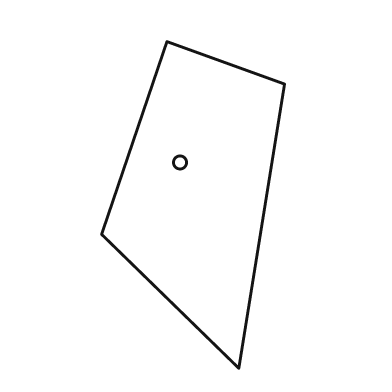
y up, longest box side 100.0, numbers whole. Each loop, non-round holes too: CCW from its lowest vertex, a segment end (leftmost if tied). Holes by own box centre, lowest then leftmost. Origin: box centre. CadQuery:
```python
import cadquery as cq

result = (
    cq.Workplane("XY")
    .moveTo(14.0, -50.0)
    .lineTo(28.0, 37.0)
    .lineTo(-8.0, 50.0)
    .lineTo(-28.0, -9.0)
    .close()
    .moveTo(-4.0, 13.0)
    .circle(2.0)
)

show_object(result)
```